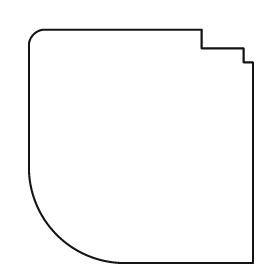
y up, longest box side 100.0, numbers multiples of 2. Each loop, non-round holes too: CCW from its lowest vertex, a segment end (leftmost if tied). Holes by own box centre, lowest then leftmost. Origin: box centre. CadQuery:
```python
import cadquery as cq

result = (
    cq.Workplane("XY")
    .moveTo(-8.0, -50.0)
    .lineTo(48.0, -50.0)
    .lineTo(48.0, 36.0)
    .lineTo(44.0, 36.0)
    .lineTo(44.0, 42.0)
    .lineTo(26.0, 42.0)
    .lineTo(26.0, 50.0)
    .lineTo(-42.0, 50.0)
    .threePointArc((-46.0, 48.0), (-48.0, 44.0))
    .lineTo(-48.0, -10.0)
    .threePointArc((-36.0, -38.0), (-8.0, -50.0))
    .close()
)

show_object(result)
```